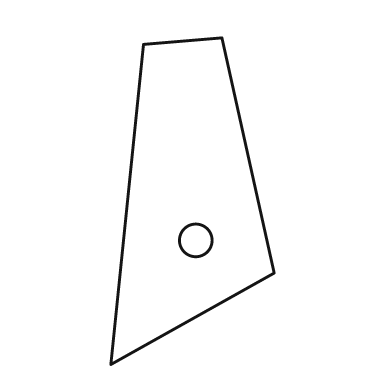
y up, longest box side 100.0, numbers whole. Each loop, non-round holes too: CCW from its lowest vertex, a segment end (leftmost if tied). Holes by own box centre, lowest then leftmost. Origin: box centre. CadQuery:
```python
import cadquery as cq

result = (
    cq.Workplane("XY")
    .moveTo(-25.0, -50.0)
    .lineTo(25.0, -22.0)
    .lineTo(9.0, 50.0)
    .lineTo(-15.0, 48.0)
    .close()
    .moveTo(1.0, -12.0)
    .circle(5.0)
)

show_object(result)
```